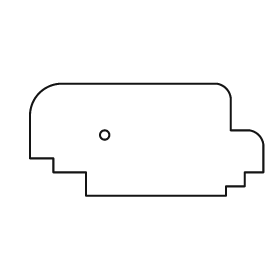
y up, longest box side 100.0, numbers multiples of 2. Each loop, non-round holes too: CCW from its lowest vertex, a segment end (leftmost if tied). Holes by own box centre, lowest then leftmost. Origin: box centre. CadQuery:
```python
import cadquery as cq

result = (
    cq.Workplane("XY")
    .moveTo(-26.0, -24.0)
    .lineTo(34.0, -24.0)
    .lineTo(34.0, -20.0)
    .lineTo(42.0, -20.0)
    .lineTo(42.0, -14.0)
    .lineTo(50.0, -14.0)
    .lineTo(50.0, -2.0)
    .threePointArc((48.0, 2.0), (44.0, 4.0))
    .lineTo(36.0, 4.0)
    .lineTo(36.0, 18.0)
    .threePointArc((34.0, 22.0), (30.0, 24.0))
    .lineTo(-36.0, 24.0)
    .threePointArc((-46.0, 20.0), (-50.0, 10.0))
    .lineTo(-50.0, -8.0)
    .lineTo(-40.0, -8.0)
    .lineTo(-40.0, -14.0)
    .lineTo(-26.0, -14.0)
    .close()
    .moveTo(-18.0, 2.0)
    .circle(2.0)
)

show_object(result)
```